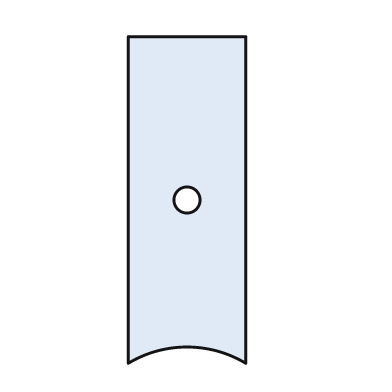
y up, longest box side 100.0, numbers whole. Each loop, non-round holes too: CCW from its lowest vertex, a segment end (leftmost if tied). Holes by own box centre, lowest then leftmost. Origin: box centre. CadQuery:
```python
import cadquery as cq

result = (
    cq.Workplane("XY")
    .moveTo(-18.0, -50.0)
    .threePointArc((0.0, -45.0), (18.0, -50.0))
    .lineTo(18.0, 50.0)
    .lineTo(-18.0, 50.0)
    .close()
    .moveTo(0.0, 0.0)
    .circle(4.0)
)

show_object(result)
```